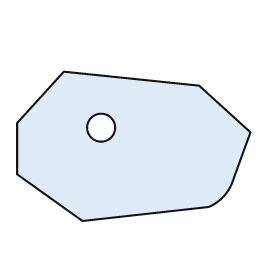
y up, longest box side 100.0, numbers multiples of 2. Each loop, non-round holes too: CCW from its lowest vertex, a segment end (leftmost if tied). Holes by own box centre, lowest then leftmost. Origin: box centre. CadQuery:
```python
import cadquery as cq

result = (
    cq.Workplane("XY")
    .moveTo(-22.0, -32.0)
    .lineTo(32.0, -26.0)
    .threePointArc((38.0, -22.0), (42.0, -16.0))
    .lineTo(50.0, 6.0)
    .lineTo(28.0, 26.0)
    .lineTo(-30.0, 32.0)
    .lineTo(-50.0, 10.0)
    .lineTo(-50.0, -12.0)
    .close()
    .moveTo(-14.0, 8.0)
    .circle(6.0)
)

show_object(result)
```